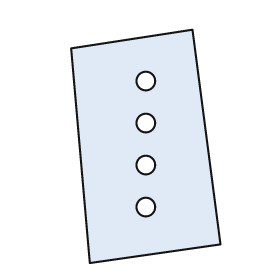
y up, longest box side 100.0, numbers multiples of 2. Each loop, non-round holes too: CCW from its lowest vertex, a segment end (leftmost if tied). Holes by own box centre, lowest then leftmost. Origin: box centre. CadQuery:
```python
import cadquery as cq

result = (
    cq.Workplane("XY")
    .moveTo(-24.0, -50.0)
    .lineTo(32.0, -42.0)
    .lineTo(20.0, 50.0)
    .lineTo(-32.0, 42.0)
    .close()
    .moveTo(0.0, -26.0)
    .circle(4.0)
    .moveTo(0.0, -8.0)
    .circle(4.0)
    .moveTo(0.0, 10.0)
    .circle(4.0)
    .moveTo(0.0, 28.0)
    .circle(4.0)
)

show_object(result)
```